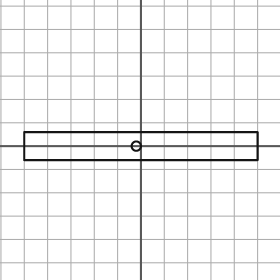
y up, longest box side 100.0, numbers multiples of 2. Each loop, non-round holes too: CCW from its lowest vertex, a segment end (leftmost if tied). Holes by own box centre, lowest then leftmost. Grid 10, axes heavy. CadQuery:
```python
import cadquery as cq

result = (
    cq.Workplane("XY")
    .moveTo(-50.0, -6.0)
    .lineTo(50.0, -6.0)
    .lineTo(50.0, 6.0)
    .lineTo(-50.0, 6.0)
    .close()
    .moveTo(-2.0, 0.0)
    .circle(2.0)
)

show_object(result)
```